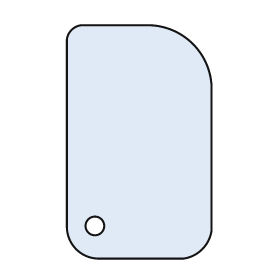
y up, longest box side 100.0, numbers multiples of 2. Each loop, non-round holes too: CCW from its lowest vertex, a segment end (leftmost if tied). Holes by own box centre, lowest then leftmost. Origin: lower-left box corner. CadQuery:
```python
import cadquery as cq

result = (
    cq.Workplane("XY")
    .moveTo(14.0, 0.0)
    .lineTo(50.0, 0.0)
    .threePointArc((58.0, 4.0), (62.0, 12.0))
    .lineTo(62.0, 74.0)
    .threePointArc((54.0, 92.0), (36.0, 100.0))
    .lineTo(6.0, 100.0)
    .threePointArc((2.0, 98.0), (0.0, 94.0))
    .lineTo(0.0, 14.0)
    .threePointArc((4.0, 4.0), (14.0, 0.0))
    .close()
    .moveTo(12.0, 14.0)
    .circle(4.0)
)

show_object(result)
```